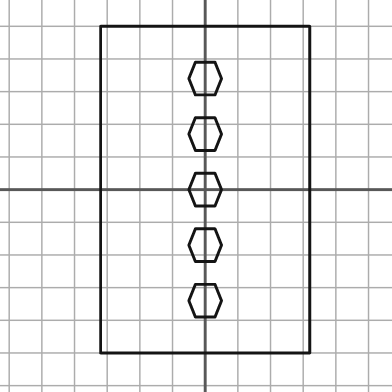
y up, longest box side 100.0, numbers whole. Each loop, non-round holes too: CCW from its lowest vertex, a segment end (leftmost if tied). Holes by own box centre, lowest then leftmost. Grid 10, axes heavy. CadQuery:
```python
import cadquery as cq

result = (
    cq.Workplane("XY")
    .moveTo(-32.0, -50.0)
    .lineTo(32.0, -50.0)
    .lineTo(32.0, 50.0)
    .lineTo(-32.0, 50.0)
    .close()
    .moveTo(-3.0, -39.0)
    .lineTo(3.0, -39.0)
    .lineTo(5.0, -34.0)
    .lineTo(3.0, -29.0)
    .lineTo(-3.0, -29.0)
    .lineTo(-5.0, -34.0)
    .close()
    .moveTo(-3.0, -22.0)
    .lineTo(3.0, -22.0)
    .lineTo(5.0, -17.0)
    .lineTo(3.0, -12.0)
    .lineTo(-3.0, -12.0)
    .lineTo(-5.0, -17.0)
    .close()
    .moveTo(-3.0, -5.0)
    .lineTo(3.0, -5.0)
    .lineTo(5.0, 0.0)
    .lineTo(3.0, 5.0)
    .lineTo(-3.0, 5.0)
    .lineTo(-5.0, 0.0)
    .close()
    .moveTo(-3.0, 12.0)
    .lineTo(3.0, 12.0)
    .lineTo(5.0, 17.0)
    .lineTo(3.0, 22.0)
    .lineTo(-3.0, 22.0)
    .lineTo(-5.0, 17.0)
    .close()
    .moveTo(-3.0, 29.0)
    .lineTo(3.0, 29.0)
    .lineTo(5.0, 34.0)
    .lineTo(3.0, 39.0)
    .lineTo(-3.0, 39.0)
    .lineTo(-5.0, 34.0)
    .close()
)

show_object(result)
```